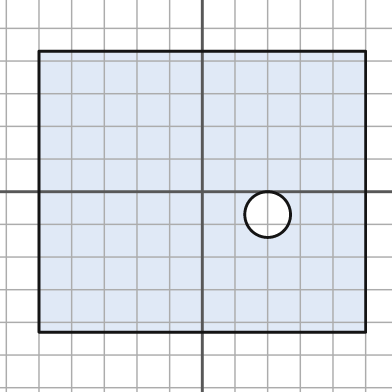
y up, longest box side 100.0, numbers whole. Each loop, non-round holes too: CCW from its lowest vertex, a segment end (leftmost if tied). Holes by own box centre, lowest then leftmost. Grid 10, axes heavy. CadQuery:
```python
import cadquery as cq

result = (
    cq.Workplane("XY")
    .moveTo(-50.0, -43.0)
    .lineTo(50.0, -43.0)
    .lineTo(50.0, 43.0)
    .lineTo(-50.0, 43.0)
    .close()
    .moveTo(20.0, -7.0)
    .circle(7.0)
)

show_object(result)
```